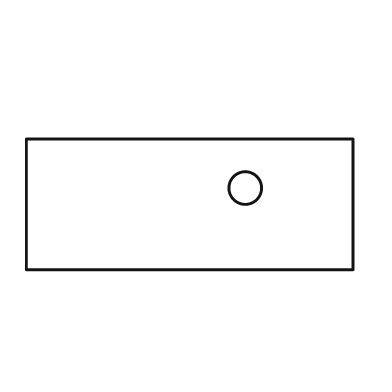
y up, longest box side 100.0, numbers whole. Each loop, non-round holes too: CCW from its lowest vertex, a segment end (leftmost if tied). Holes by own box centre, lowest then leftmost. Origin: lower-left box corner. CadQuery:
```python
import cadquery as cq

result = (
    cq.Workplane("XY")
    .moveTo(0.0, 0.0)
    .lineTo(100.0, 0.0)
    .lineTo(100.0, 40.0)
    .lineTo(0.0, 40.0)
    .close()
    .moveTo(67.0, 25.0)
    .circle(5.0)
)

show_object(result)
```